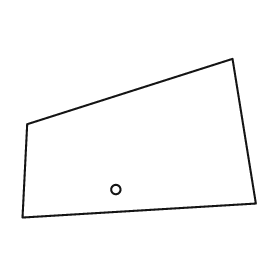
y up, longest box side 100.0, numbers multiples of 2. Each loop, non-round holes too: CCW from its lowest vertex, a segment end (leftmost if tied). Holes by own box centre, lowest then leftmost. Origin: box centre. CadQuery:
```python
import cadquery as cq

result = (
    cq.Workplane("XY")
    .moveTo(-50.0, -34.0)
    .lineTo(50.0, -28.0)
    .lineTo(40.0, 34.0)
    .lineTo(-48.0, 6.0)
    .close()
    .moveTo(-10.0, -22.0)
    .circle(2.0)
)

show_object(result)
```